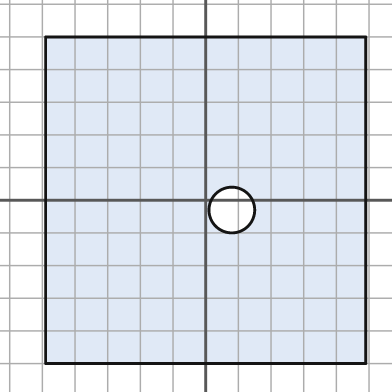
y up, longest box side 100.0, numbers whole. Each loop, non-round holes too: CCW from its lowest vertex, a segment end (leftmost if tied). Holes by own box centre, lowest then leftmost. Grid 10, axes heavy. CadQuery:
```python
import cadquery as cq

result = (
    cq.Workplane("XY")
    .moveTo(-49.0, -50.0)
    .lineTo(49.0, -50.0)
    .lineTo(49.0, 50.0)
    .lineTo(-49.0, 50.0)
    .close()
    .moveTo(8.0, -3.0)
    .circle(7.0)
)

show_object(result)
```